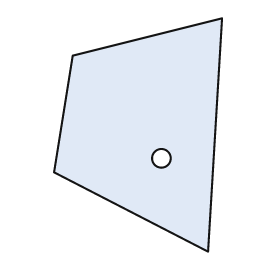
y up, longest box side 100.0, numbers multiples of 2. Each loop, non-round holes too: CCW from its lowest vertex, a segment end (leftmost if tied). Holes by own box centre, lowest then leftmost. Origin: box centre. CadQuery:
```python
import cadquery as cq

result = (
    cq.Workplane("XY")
    .moveTo(30.0, -50.0)
    .lineTo(36.0, 50.0)
    .lineTo(-28.0, 34.0)
    .lineTo(-36.0, -16.0)
    .close()
    .moveTo(10.0, -10.0)
    .circle(4.0)
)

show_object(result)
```